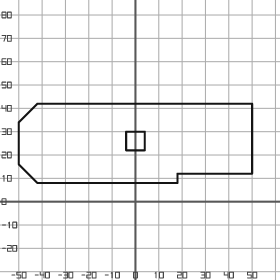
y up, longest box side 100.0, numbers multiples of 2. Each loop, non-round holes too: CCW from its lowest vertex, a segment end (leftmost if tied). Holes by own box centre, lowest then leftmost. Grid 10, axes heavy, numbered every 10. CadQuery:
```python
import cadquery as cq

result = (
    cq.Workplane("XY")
    .moveTo(-42.0, 8.0)
    .lineTo(18.0, 8.0)
    .lineTo(18.0, 12.0)
    .lineTo(50.0, 12.0)
    .lineTo(50.0, 42.0)
    .lineTo(-42.0, 42.0)
    .lineTo(-50.0, 34.0)
    .lineTo(-50.0, 16.0)
    .close()
    .moveTo(-4.0, 22.0)
    .lineTo(4.0, 22.0)
    .lineTo(4.0, 30.0)
    .lineTo(-4.0, 30.0)
    .close()
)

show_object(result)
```